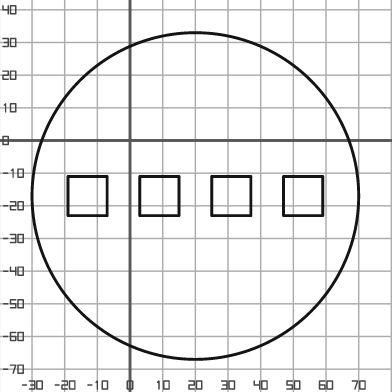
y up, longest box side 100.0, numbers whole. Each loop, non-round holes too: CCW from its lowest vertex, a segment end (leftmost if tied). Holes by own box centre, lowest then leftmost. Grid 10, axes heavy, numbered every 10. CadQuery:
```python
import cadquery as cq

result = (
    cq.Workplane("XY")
    .moveTo(20.0, -17.0)
    .circle(50.0)
    .moveTo(-19.0, -23.0)
    .lineTo(-7.0, -23.0)
    .lineTo(-7.0, -11.0)
    .lineTo(-19.0, -11.0)
    .close()
    .moveTo(3.0, -23.0)
    .lineTo(15.0, -23.0)
    .lineTo(15.0, -11.0)
    .lineTo(3.0, -11.0)
    .close()
    .moveTo(25.0, -23.0)
    .lineTo(37.0, -23.0)
    .lineTo(37.0, -11.0)
    .lineTo(25.0, -11.0)
    .close()
    .moveTo(47.0, -23.0)
    .lineTo(59.0, -23.0)
    .lineTo(59.0, -11.0)
    .lineTo(47.0, -11.0)
    .close()
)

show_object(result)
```